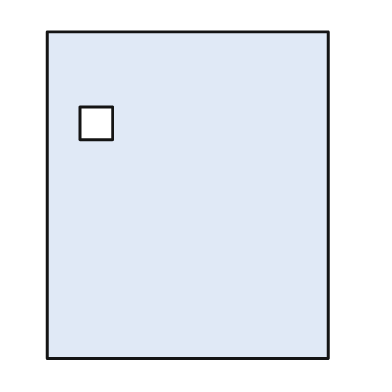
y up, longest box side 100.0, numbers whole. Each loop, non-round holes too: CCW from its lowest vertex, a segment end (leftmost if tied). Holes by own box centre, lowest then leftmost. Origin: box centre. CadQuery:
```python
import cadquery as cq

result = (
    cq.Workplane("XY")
    .moveTo(-43.0, -50.0)
    .lineTo(43.0, -50.0)
    .lineTo(43.0, 50.0)
    .lineTo(-43.0, 50.0)
    .close()
    .moveTo(-33.0, 17.0)
    .lineTo(-23.0, 17.0)
    .lineTo(-23.0, 27.0)
    .lineTo(-33.0, 27.0)
    .close()
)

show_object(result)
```